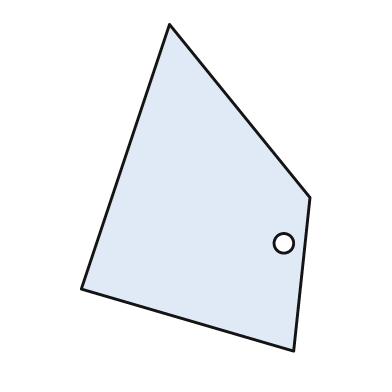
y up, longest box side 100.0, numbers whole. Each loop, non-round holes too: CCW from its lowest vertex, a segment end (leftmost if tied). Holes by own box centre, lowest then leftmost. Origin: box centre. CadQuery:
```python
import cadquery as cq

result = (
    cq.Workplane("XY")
    .moveTo(30.0, -50.0)
    .lineTo(35.0, -3.0)
    .lineTo(-8.0, 50.0)
    .lineTo(-35.0, -31.0)
    .close()
    .moveTo(27.0, -17.0)
    .circle(3.0)
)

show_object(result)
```